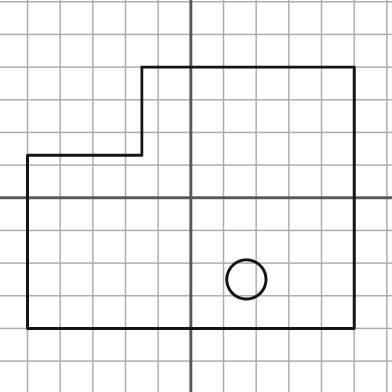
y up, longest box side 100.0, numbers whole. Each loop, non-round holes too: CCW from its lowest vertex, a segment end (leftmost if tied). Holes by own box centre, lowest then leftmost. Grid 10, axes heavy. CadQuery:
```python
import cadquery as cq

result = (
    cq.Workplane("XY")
    .moveTo(-50.0, -40.0)
    .lineTo(50.0, -40.0)
    .lineTo(50.0, 40.0)
    .lineTo(-15.0, 40.0)
    .lineTo(-15.0, 13.0)
    .lineTo(-50.0, 13.0)
    .close()
    .moveTo(17.0, -25.0)
    .circle(6.0)
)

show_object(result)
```